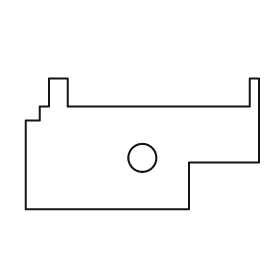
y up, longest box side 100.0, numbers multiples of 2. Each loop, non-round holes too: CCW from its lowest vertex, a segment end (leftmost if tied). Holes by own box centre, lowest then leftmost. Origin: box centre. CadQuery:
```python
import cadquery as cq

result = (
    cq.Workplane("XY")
    .moveTo(-50.0, -28.0)
    .lineTo(20.0, -28.0)
    .lineTo(20.0, -8.0)
    .lineTo(50.0, -8.0)
    .lineTo(50.0, 28.0)
    .lineTo(46.0, 28.0)
    .lineTo(46.0, 16.0)
    .lineTo(-32.0, 16.0)
    .lineTo(-32.0, 28.0)
    .lineTo(-40.0, 28.0)
    .lineTo(-40.0, 16.0)
    .lineTo(-44.0, 16.0)
    .lineTo(-44.0, 10.0)
    .lineTo(-50.0, 10.0)
    .close()
    .moveTo(0.0, -6.0)
    .circle(6.0)
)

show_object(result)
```